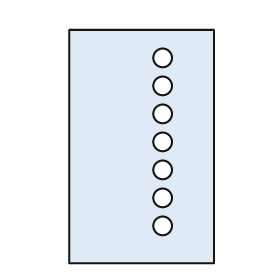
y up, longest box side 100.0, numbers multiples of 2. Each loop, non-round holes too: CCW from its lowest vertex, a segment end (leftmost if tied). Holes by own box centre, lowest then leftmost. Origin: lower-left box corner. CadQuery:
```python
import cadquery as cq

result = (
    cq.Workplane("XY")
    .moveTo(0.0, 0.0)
    .lineTo(62.0, 0.0)
    .lineTo(62.0, 100.0)
    .lineTo(0.0, 100.0)
    .close()
    .moveTo(40.0, 16.0)
    .circle(4.0)
    .moveTo(40.0, 28.0)
    .circle(4.0)
    .moveTo(40.0, 40.0)
    .circle(4.0)
    .moveTo(40.0, 52.0)
    .circle(4.0)
    .moveTo(40.0, 64.0)
    .circle(4.0)
    .moveTo(40.0, 76.0)
    .circle(4.0)
    .moveTo(40.0, 88.0)
    .circle(4.0)
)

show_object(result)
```